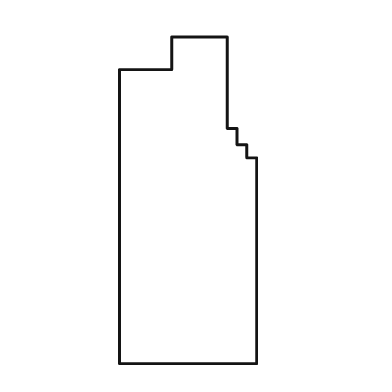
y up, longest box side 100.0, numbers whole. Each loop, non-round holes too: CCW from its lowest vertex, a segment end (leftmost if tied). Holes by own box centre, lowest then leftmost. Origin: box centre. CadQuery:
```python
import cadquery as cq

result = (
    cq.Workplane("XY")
    .moveTo(-21.0, -50.0)
    .lineTo(21.0, -50.0)
    .lineTo(21.0, 13.0)
    .lineTo(18.0, 13.0)
    .lineTo(18.0, 17.0)
    .lineTo(15.0, 17.0)
    .lineTo(15.0, 22.0)
    .lineTo(12.0, 22.0)
    .lineTo(12.0, 50.0)
    .lineTo(-5.0, 50.0)
    .lineTo(-5.0, 40.0)
    .lineTo(-21.0, 40.0)
    .close()
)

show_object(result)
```